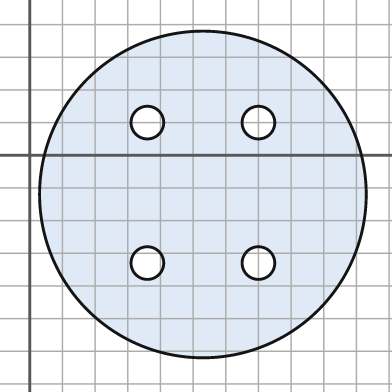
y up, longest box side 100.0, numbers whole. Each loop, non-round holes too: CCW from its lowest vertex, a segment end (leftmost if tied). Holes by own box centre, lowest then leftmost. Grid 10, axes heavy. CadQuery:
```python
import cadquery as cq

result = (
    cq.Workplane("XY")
    .moveTo(53.0, -12.0)
    .circle(50.0)
    .moveTo(36.0, -33.0)
    .circle(5.0)
    .moveTo(70.0, -33.0)
    .circle(5.0)
    .moveTo(36.0, 10.0)
    .circle(5.0)
    .moveTo(70.0, 10.0)
    .circle(5.0)
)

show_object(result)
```